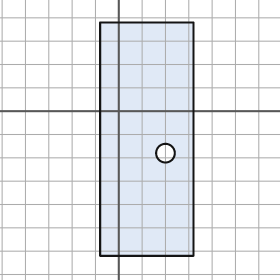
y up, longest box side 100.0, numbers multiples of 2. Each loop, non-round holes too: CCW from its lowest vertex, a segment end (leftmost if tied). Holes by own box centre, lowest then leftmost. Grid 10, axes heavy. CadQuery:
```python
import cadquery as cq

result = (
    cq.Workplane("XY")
    .moveTo(-8.0, -62.0)
    .lineTo(32.0, -62.0)
    .lineTo(32.0, 38.0)
    .lineTo(-8.0, 38.0)
    .close()
    .moveTo(20.0, -18.0)
    .circle(4.0)
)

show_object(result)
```